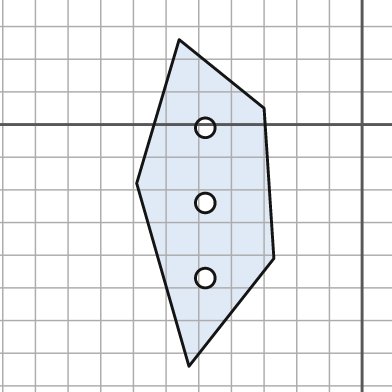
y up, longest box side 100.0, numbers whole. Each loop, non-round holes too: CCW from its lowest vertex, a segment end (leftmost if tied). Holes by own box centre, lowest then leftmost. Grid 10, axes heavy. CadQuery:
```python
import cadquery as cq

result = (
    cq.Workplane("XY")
    .moveTo(-53.0, -74.0)
    .lineTo(-27.0, -41.0)
    .lineTo(-30.0, 5.0)
    .lineTo(-56.0, 26.0)
    .lineTo(-69.0, -18.0)
    .close()
    .moveTo(-48.0, -47.0)
    .circle(3.0)
    .moveTo(-48.0, -24.0)
    .circle(3.0)
    .moveTo(-48.0, -1.0)
    .circle(3.0)
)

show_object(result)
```